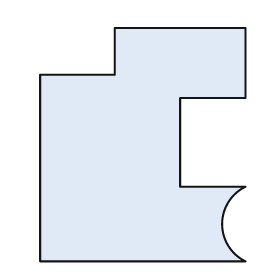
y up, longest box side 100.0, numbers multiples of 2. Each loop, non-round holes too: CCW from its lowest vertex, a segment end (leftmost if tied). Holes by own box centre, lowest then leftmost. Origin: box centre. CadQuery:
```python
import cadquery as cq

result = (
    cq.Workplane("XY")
    .moveTo(-44.0, -50.0)
    .lineTo(44.0, -50.0)
    .threePointArc((34.0, -34.0), (44.0, -18.0))
    .lineTo(16.0, -18.0)
    .lineTo(16.0, 20.0)
    .lineTo(44.0, 20.0)
    .lineTo(44.0, 50.0)
    .lineTo(-12.0, 50.0)
    .lineTo(-12.0, 30.0)
    .lineTo(-44.0, 30.0)
    .close()
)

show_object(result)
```